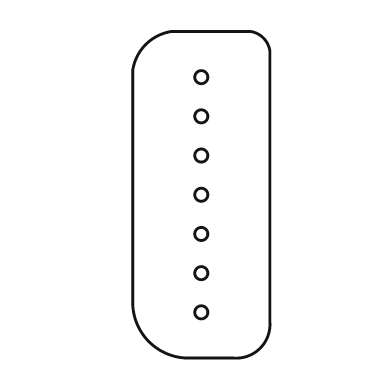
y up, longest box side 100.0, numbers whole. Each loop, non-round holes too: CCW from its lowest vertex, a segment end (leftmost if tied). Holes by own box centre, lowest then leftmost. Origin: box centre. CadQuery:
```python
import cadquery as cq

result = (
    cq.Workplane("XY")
    .moveTo(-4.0, -50.0)
    .lineTo(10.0, -50.0)
    .threePointArc((18.0, -47.0), (21.0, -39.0))
    .lineTo(21.0, 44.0)
    .threePointArc((19.0, 48.0), (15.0, 50.0))
    .lineTo(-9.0, 50.0)
    .threePointArc((-17.0, 46.0), (-21.0, 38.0))
    .lineTo(-21.0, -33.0)
    .threePointArc((-16.0, -45.0), (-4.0, -50.0))
    .close()
    .moveTo(0.0, -36.0)
    .circle(2.0)
    .moveTo(0.0, -24.0)
    .circle(2.0)
    .moveTo(0.0, -12.0)
    .circle(2.0)
    .moveTo(0.0, 0.0)
    .circle(2.0)
    .moveTo(0.0, 12.0)
    .circle(2.0)
    .moveTo(0.0, 24.0)
    .circle(2.0)
    .moveTo(0.0, 36.0)
    .circle(2.0)
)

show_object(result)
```